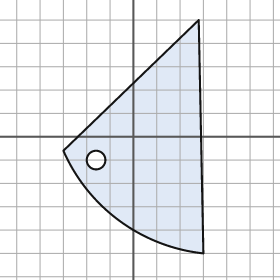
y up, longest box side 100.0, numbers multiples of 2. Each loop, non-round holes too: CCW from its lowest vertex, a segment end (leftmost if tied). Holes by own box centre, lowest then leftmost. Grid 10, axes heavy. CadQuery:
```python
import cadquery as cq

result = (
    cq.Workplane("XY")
    .moveTo(30.0, -50.0)
    .lineTo(28.0, 50.0)
    .lineTo(-30.0, -6.0)
    .threePointArc((-6.0, -36.0), (30.0, -50.0))
    .close()
    .moveTo(-16.0, -10.0)
    .circle(4.0)
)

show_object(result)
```